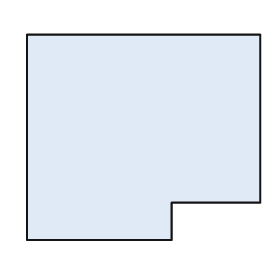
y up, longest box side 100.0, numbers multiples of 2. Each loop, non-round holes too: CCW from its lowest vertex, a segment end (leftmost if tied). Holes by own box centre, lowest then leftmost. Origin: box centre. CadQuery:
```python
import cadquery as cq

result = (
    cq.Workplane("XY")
    .moveTo(-50.0, -44.0)
    .lineTo(12.0, -44.0)
    .lineTo(12.0, -28.0)
    .lineTo(50.0, -28.0)
    .lineTo(50.0, 44.0)
    .lineTo(-50.0, 44.0)
    .close()
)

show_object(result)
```